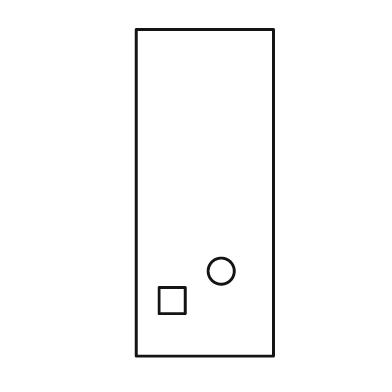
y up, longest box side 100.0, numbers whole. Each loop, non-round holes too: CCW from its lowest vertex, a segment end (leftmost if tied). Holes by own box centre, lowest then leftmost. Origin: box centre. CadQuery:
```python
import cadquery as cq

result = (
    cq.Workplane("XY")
    .moveTo(-21.0, -50.0)
    .lineTo(21.0, -50.0)
    .lineTo(21.0, 50.0)
    .lineTo(-21.0, 50.0)
    .close()
    .moveTo(-14.0, -37.0)
    .lineTo(-6.0, -37.0)
    .lineTo(-6.0, -29.0)
    .lineTo(-14.0, -29.0)
    .close()
    .moveTo(5.0, -24.0)
    .circle(4.0)
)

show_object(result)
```